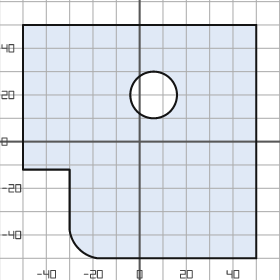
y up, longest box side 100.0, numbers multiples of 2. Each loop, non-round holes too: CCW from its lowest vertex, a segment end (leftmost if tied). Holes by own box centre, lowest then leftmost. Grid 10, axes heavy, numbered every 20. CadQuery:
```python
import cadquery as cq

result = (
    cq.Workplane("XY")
    .moveTo(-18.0, -50.0)
    .lineTo(50.0, -50.0)
    .lineTo(50.0, 50.0)
    .lineTo(-50.0, 50.0)
    .lineTo(-50.0, -12.0)
    .lineTo(-30.0, -12.0)
    .lineTo(-30.0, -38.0)
    .threePointArc((-26.0, -46.0), (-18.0, -50.0))
    .close()
    .moveTo(6.0, 20.0)
    .circle(10.0)
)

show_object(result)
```